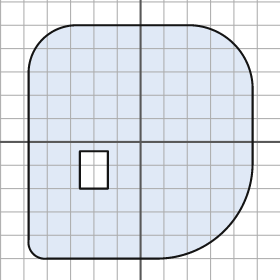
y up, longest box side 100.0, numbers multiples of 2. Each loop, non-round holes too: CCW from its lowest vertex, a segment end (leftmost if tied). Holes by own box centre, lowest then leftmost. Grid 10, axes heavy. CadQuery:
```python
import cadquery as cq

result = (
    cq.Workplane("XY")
    .moveTo(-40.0, -50.0)
    .lineTo(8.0, -50.0)
    .threePointArc((36.0, -38.0), (48.0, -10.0))
    .lineTo(48.0, 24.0)
    .threePointArc((40.0, 42.0), (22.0, 50.0))
    .lineTo(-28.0, 50.0)
    .threePointArc((-42.0, 44.0), (-48.0, 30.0))
    .lineTo(-48.0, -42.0)
    .threePointArc((-46.0, -48.0), (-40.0, -50.0))
    .close()
    .moveTo(-26.0, -20.0)
    .lineTo(-14.0, -20.0)
    .lineTo(-14.0, -4.0)
    .lineTo(-26.0, -4.0)
    .close()
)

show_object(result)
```